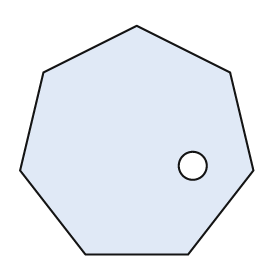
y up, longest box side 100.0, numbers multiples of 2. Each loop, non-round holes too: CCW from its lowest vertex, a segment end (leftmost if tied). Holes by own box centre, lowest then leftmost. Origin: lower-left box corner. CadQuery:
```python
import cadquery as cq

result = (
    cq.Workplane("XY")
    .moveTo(28.0, 0.0)
    .lineTo(72.0, 0.0)
    .lineTo(100.0, 36.0)
    .lineTo(90.0, 78.0)
    .lineTo(50.0, 98.0)
    .lineTo(10.0, 78.0)
    .lineTo(0.0, 36.0)
    .close()
    .moveTo(74.0, 38.0)
    .circle(6.0)
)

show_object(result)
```